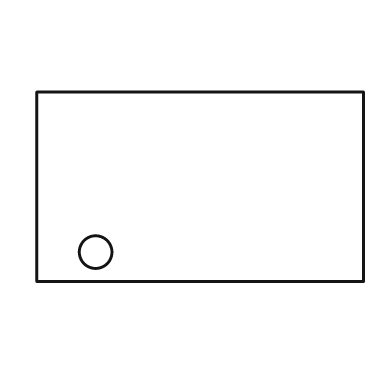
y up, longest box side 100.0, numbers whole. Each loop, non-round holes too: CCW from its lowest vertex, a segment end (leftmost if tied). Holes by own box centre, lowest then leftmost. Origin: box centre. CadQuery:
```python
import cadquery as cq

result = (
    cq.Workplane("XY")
    .moveTo(-50.0, -29.0)
    .lineTo(50.0, -29.0)
    .lineTo(50.0, 29.0)
    .lineTo(-50.0, 29.0)
    .close()
    .moveTo(-32.0, -20.0)
    .circle(5.0)
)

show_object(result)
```